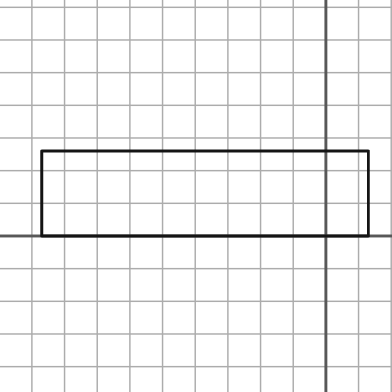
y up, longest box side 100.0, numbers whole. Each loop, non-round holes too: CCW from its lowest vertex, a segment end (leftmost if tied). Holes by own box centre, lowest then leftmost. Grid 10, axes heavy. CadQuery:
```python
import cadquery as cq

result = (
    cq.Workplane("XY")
    .moveTo(-87.0, 0.0)
    .lineTo(13.0, 0.0)
    .lineTo(13.0, 26.0)
    .lineTo(-87.0, 26.0)
    .close()
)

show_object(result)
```